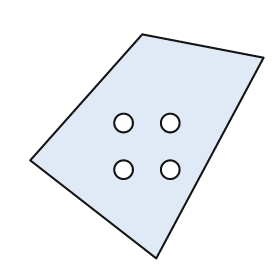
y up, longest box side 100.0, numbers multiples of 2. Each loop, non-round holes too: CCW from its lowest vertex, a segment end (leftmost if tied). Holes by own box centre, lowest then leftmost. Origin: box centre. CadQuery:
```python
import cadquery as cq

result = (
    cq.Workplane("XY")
    .moveTo(4.0, -48.0)
    .lineTo(50.0, 38.0)
    .lineTo(-2.0, 48.0)
    .lineTo(-50.0, -6.0)
    .close()
    .moveTo(-10.0, -10.0)
    .circle(4.0)
    .moveTo(10.0, -10.0)
    .circle(4.0)
    .moveTo(-10.0, 10.0)
    .circle(4.0)
    .moveTo(10.0, 10.0)
    .circle(4.0)
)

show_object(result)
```